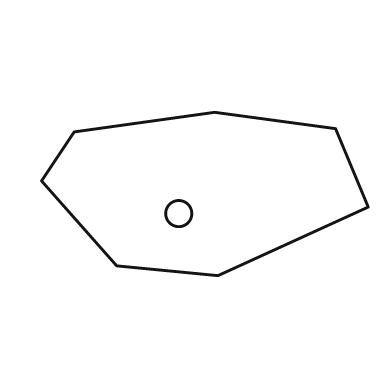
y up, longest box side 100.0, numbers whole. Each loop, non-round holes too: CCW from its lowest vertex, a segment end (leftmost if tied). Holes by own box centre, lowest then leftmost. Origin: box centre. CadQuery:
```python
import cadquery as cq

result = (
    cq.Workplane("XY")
    .moveTo(4.0, -25.0)
    .lineTo(50.0, -4.0)
    .lineTo(40.0, 20.0)
    .lineTo(3.0, 25.0)
    .lineTo(-40.0, 19.0)
    .lineTo(-50.0, 4.0)
    .lineTo(-27.0, -22.0)
    .close()
    .moveTo(-8.0, -6.0)
    .circle(4.0)
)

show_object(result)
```